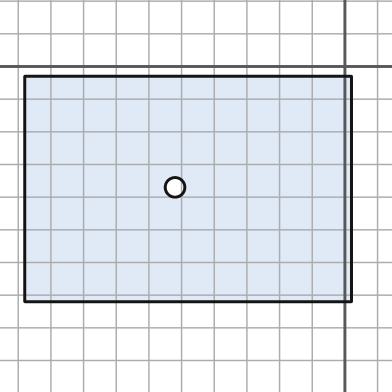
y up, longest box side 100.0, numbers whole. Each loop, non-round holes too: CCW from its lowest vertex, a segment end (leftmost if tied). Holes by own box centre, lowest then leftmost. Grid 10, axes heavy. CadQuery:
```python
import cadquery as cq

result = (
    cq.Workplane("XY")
    .moveTo(-98.0, -72.0)
    .lineTo(2.0, -72.0)
    .lineTo(2.0, -3.0)
    .lineTo(-98.0, -3.0)
    .close()
    .moveTo(-52.0, -37.0)
    .circle(3.0)
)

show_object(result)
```